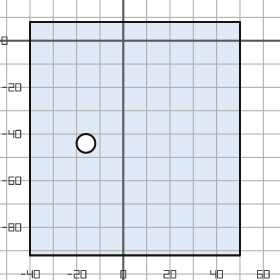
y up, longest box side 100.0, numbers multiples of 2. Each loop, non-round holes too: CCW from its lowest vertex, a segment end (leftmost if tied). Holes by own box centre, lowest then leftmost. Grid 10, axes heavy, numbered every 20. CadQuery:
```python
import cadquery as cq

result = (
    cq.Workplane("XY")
    .moveTo(-40.0, -92.0)
    .lineTo(50.0, -92.0)
    .lineTo(50.0, 8.0)
    .lineTo(-40.0, 8.0)
    .close()
    .moveTo(-16.0, -44.0)
    .circle(4.0)
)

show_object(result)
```